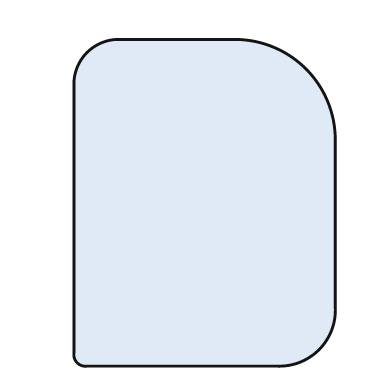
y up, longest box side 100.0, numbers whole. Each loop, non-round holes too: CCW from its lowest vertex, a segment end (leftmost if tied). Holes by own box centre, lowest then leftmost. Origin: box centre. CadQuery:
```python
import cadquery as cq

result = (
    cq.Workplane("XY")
    .moveTo(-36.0, -50.0)
    .lineTo(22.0, -50.0)
    .threePointArc((35.0, -45.0), (40.0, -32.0))
    .lineTo(40.0, 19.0)
    .threePointArc((31.0, 41.0), (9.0, 50.0))
    .lineTo(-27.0, 50.0)
    .threePointArc((-36.0, 46.0), (-40.0, 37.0))
    .lineTo(-40.0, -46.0)
    .threePointArc((-39.0, -49.0), (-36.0, -50.0))
    .close()
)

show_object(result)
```